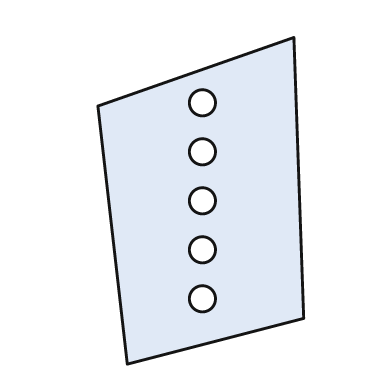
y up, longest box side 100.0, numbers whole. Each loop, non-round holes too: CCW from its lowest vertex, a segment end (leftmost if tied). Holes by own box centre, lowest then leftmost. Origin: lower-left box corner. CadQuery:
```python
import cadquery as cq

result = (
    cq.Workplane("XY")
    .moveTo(9.0, 0.0)
    .lineTo(63.0, 14.0)
    .lineTo(60.0, 100.0)
    .lineTo(0.0, 79.0)
    .close()
    .moveTo(32.0, 20.0)
    .circle(4.0)
    .moveTo(32.0, 35.0)
    .circle(4.0)
    .moveTo(32.0, 50.0)
    .circle(4.0)
    .moveTo(32.0, 65.0)
    .circle(4.0)
    .moveTo(32.0, 80.0)
    .circle(4.0)
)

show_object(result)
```